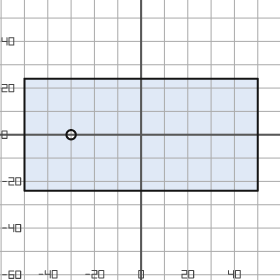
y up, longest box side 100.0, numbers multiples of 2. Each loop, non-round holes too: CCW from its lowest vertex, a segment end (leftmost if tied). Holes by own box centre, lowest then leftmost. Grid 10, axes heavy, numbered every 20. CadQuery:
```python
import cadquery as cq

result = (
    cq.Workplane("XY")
    .moveTo(-50.0, -24.0)
    .lineTo(50.0, -24.0)
    .lineTo(50.0, 24.0)
    .lineTo(-50.0, 24.0)
    .close()
    .moveTo(-30.0, 0.0)
    .circle(2.0)
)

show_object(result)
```